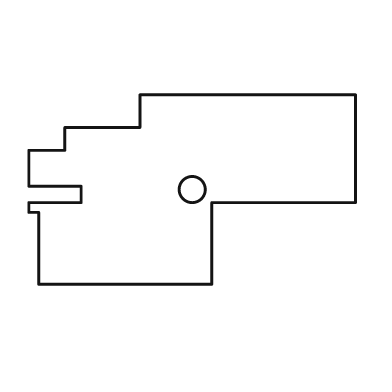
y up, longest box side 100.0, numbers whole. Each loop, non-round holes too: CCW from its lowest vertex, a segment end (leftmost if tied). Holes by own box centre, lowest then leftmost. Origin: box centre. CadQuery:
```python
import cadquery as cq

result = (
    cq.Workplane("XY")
    .moveTo(-47.0, -29.0)
    .lineTo(6.0, -29.0)
    .lineTo(6.0, -4.0)
    .lineTo(50.0, -4.0)
    .lineTo(50.0, 29.0)
    .lineTo(-16.0, 29.0)
    .lineTo(-16.0, 19.0)
    .lineTo(-39.0, 19.0)
    .lineTo(-39.0, 12.0)
    .lineTo(-50.0, 12.0)
    .lineTo(-50.0, 1.0)
    .lineTo(-34.0, 1.0)
    .lineTo(-34.0, -4.0)
    .lineTo(-50.0, -4.0)
    .lineTo(-50.0, -7.0)
    .lineTo(-47.0, -7.0)
    .close()
    .moveTo(0.0, 0.0)
    .circle(4.0)
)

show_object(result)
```